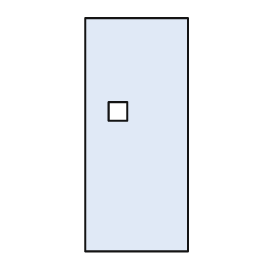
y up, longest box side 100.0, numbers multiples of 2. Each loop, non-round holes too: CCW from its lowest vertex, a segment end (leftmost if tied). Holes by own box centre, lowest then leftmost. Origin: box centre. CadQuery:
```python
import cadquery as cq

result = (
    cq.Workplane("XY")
    .moveTo(-22.0, -50.0)
    .lineTo(22.0, -50.0)
    .lineTo(22.0, 50.0)
    .lineTo(-22.0, 50.0)
    .close()
    .moveTo(-12.0, 6.0)
    .lineTo(-4.0, 6.0)
    .lineTo(-4.0, 14.0)
    .lineTo(-12.0, 14.0)
    .close()
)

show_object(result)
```